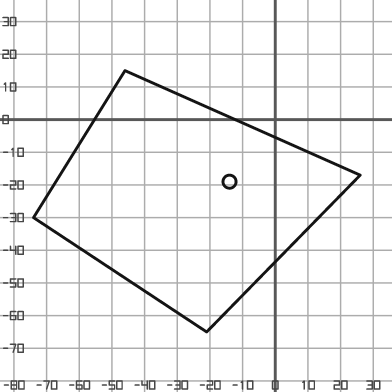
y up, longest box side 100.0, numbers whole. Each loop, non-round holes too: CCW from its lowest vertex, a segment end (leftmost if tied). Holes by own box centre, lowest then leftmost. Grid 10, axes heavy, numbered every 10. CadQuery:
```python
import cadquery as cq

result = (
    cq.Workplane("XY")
    .moveTo(-21.0, -65.0)
    .lineTo(26.0, -17.0)
    .lineTo(-46.0, 15.0)
    .lineTo(-74.0, -30.0)
    .close()
    .moveTo(-14.0, -19.0)
    .circle(2.0)
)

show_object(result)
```